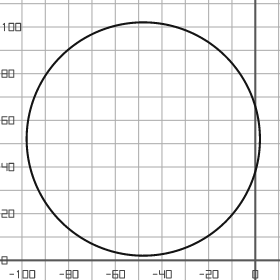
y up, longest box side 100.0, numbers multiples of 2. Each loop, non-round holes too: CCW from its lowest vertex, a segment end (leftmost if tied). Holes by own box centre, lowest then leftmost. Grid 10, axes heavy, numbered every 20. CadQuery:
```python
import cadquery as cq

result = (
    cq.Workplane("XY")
    .moveTo(-48.0, 52.0)
    .circle(50.0)
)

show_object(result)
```